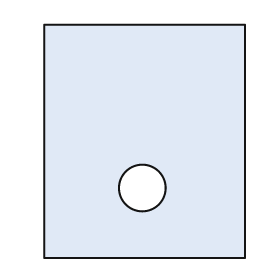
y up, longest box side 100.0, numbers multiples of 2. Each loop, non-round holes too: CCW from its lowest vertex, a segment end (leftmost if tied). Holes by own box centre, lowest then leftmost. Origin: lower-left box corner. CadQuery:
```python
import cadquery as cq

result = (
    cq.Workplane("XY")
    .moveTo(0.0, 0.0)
    .lineTo(86.0, 0.0)
    .lineTo(86.0, 100.0)
    .lineTo(0.0, 100.0)
    .close()
    .moveTo(42.0, 30.0)
    .circle(10.0)
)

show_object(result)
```